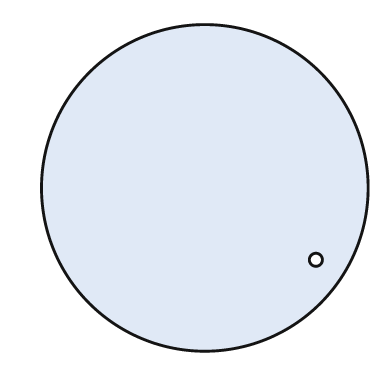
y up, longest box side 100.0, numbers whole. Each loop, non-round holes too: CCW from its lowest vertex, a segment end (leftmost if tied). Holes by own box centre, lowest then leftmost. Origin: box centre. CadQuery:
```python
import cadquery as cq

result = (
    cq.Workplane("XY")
    .moveTo(0.0, 0.0)
    .circle(50.0)
    .moveTo(34.0, -22.0)
    .circle(2.0)
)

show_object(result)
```